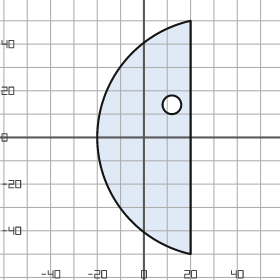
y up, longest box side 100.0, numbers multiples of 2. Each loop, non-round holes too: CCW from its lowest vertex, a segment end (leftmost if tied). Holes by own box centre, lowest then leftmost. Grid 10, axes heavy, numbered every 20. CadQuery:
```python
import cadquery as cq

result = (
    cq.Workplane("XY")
    .moveTo(20.0, -50.0)
    .lineTo(20.0, 50.0)
    .threePointArc((-20.0, 0.0), (20.0, -50.0))
    .close()
    .moveTo(12.0, 14.0)
    .circle(4.0)
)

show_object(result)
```